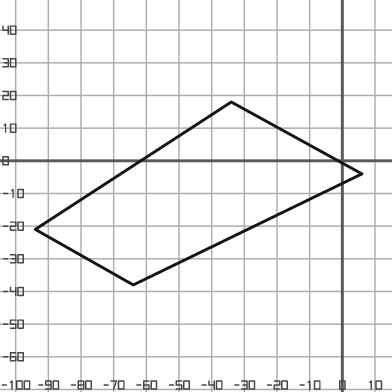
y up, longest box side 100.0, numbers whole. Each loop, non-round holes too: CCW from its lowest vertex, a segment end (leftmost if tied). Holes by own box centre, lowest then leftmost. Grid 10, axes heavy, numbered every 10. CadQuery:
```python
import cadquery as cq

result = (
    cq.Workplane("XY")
    .moveTo(-64.0, -38.0)
    .lineTo(6.0, -4.0)
    .lineTo(-34.0, 18.0)
    .lineTo(-94.0, -21.0)
    .close()
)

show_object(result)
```